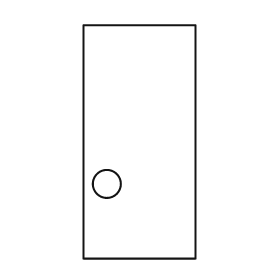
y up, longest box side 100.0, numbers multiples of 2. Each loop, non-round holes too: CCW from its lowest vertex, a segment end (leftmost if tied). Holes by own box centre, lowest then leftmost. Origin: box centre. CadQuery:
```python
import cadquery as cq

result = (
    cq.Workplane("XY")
    .moveTo(-24.0, -50.0)
    .lineTo(24.0, -50.0)
    .lineTo(24.0, 50.0)
    .lineTo(-24.0, 50.0)
    .close()
    .moveTo(-14.0, -18.0)
    .circle(6.0)
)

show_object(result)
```